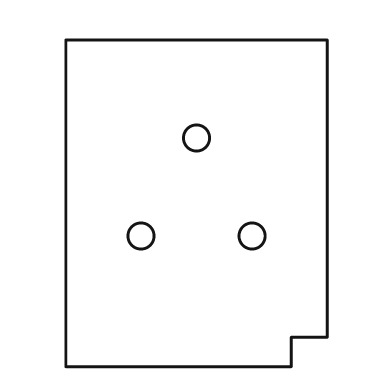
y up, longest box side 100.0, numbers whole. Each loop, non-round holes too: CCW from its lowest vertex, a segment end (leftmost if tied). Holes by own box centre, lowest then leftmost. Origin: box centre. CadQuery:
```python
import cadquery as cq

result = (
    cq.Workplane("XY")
    .moveTo(-40.0, -50.0)
    .lineTo(29.0, -50.0)
    .lineTo(29.0, -41.0)
    .lineTo(40.0, -41.0)
    .lineTo(40.0, 50.0)
    .lineTo(-40.0, 50.0)
    .close()
    .moveTo(-17.0, -10.0)
    .circle(4.0)
    .moveTo(17.0, -10.0)
    .circle(4.0)
    .moveTo(0.0, 20.0)
    .circle(4.0)
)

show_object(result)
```